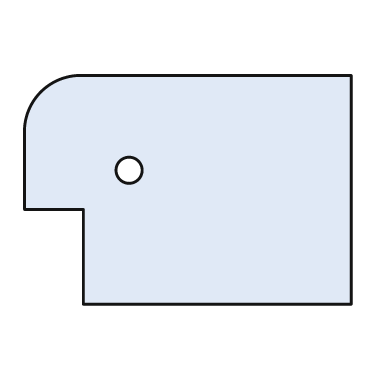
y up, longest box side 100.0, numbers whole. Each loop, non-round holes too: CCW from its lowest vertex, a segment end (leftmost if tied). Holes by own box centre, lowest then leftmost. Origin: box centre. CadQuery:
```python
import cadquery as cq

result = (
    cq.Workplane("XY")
    .moveTo(-32.0, -35.0)
    .lineTo(50.0, -35.0)
    .lineTo(50.0, 35.0)
    .lineTo(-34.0, 35.0)
    .threePointArc((-45.0, 30.0), (-50.0, 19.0))
    .lineTo(-50.0, -6.0)
    .lineTo(-32.0, -6.0)
    .close()
    .moveTo(-18.0, 6.0)
    .circle(4.0)
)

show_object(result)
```